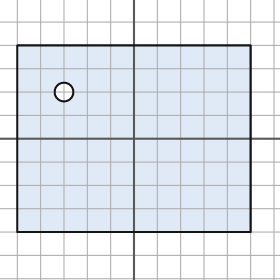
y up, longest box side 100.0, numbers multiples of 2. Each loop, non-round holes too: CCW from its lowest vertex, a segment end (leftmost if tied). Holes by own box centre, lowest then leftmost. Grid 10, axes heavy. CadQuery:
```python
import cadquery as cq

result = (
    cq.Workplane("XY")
    .moveTo(-50.0, -40.0)
    .lineTo(50.0, -40.0)
    .lineTo(50.0, 40.0)
    .lineTo(-50.0, 40.0)
    .close()
    .moveTo(-30.0, 20.0)
    .circle(4.0)
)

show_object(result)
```